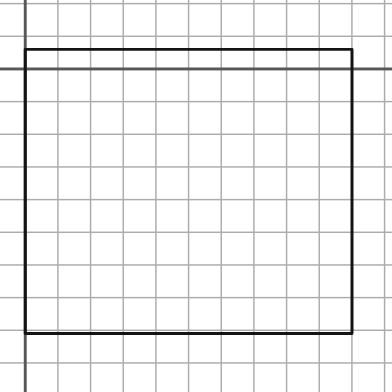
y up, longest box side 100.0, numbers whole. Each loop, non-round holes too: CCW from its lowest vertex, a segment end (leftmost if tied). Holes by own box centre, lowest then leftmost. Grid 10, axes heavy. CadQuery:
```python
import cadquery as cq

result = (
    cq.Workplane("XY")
    .moveTo(0.0, -81.0)
    .lineTo(100.0, -81.0)
    .lineTo(100.0, 6.0)
    .lineTo(0.0, 6.0)
    .close()
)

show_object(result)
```